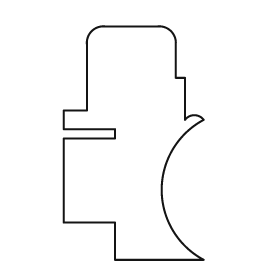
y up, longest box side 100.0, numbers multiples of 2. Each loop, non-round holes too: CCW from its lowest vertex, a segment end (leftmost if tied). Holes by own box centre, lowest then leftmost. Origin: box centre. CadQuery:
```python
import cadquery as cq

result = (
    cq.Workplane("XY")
    .moveTo(-8.0, -50.0)
    .lineTo(30.0, -50.0)
    .threePointArc((12.0, -20.0), (30.0, 10.0))
    .threePointArc((26.0, 12.0), (22.0, 10.0))
    .lineTo(22.0, 28.0)
    .lineTo(18.0, 28.0)
    .lineTo(18.0, 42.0)
    .threePointArc((16.0, 48.0), (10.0, 50.0))
    .lineTo(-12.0, 50.0)
    .threePointArc((-18.0, 48.0), (-20.0, 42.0))
    .lineTo(-20.0, 14.0)
    .lineTo(-30.0, 14.0)
    .lineTo(-30.0, 6.0)
    .lineTo(-8.0, 6.0)
    .lineTo(-8.0, 2.0)
    .lineTo(-30.0, 2.0)
    .lineTo(-30.0, -34.0)
    .lineTo(-8.0, -34.0)
    .close()
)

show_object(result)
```